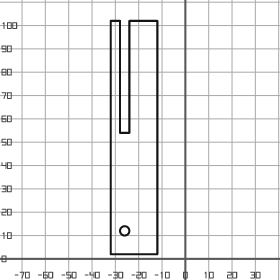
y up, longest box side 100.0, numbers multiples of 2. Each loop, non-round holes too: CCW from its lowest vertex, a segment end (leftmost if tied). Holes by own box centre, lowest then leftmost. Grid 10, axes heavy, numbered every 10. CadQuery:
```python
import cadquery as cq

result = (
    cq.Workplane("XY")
    .moveTo(-32.0, 2.0)
    .lineTo(-12.0, 2.0)
    .lineTo(-12.0, 102.0)
    .lineTo(-24.0, 102.0)
    .lineTo(-24.0, 54.0)
    .lineTo(-28.0, 54.0)
    .lineTo(-28.0, 102.0)
    .lineTo(-32.0, 102.0)
    .close()
    .moveTo(-26.0, 12.0)
    .circle(2.0)
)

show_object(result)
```